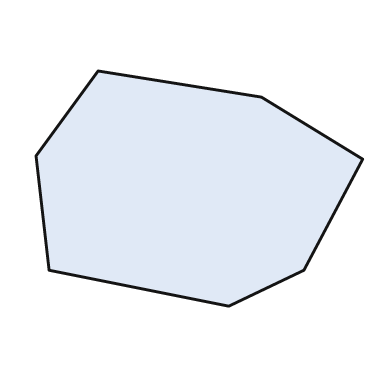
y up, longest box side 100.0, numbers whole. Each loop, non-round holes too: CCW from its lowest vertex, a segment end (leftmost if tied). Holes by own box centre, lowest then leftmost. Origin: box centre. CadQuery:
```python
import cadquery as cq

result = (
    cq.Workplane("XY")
    .moveTo(9.0, -36.0)
    .lineTo(32.0, -25.0)
    .lineTo(50.0, 9.0)
    .lineTo(19.0, 28.0)
    .lineTo(-31.0, 36.0)
    .lineTo(-50.0, 10.0)
    .lineTo(-46.0, -25.0)
    .close()
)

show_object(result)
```